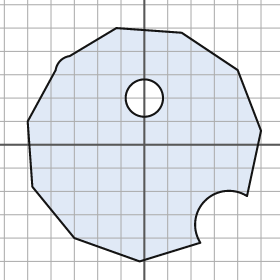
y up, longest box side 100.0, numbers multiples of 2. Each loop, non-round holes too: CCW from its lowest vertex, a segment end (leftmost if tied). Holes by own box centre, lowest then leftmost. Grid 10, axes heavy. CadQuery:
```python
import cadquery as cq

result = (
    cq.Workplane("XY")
    .moveTo(-2.0, -50.0)
    .lineTo(24.0, -42.0)
    .threePointArc((26.0, -24.0), (44.0, -22.0))
    .lineTo(50.0, 6.0)
    .lineTo(40.0, 32.0)
    .lineTo(16.0, 48.0)
    .lineTo(-12.0, 50.0)
    .lineTo(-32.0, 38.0)
    .threePointArc((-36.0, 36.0), (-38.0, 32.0))
    .lineTo(-50.0, 10.0)
    .lineTo(-48.0, -18.0)
    .lineTo(-30.0, -40.0)
    .close()
    .moveTo(0.0, 20.0)
    .circle(8.0)
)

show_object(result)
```